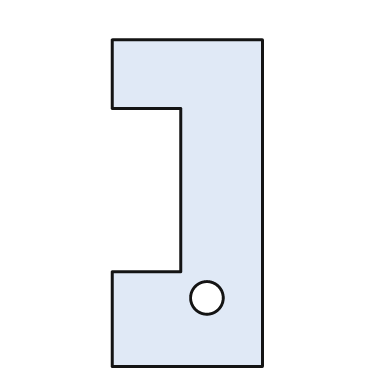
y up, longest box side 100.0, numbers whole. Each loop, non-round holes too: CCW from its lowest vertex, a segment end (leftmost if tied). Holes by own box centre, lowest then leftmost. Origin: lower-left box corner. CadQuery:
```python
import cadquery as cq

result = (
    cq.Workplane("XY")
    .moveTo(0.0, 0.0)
    .lineTo(46.0, 0.0)
    .lineTo(46.0, 100.0)
    .lineTo(0.0, 100.0)
    .lineTo(0.0, 79.0)
    .lineTo(21.0, 79.0)
    .lineTo(21.0, 29.0)
    .lineTo(0.0, 29.0)
    .close()
    .moveTo(29.0, 21.0)
    .circle(5.0)
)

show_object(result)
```